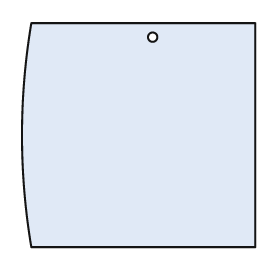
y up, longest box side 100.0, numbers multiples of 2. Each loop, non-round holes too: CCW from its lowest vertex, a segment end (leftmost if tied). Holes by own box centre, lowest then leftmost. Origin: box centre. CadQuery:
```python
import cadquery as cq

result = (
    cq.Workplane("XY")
    .moveTo(-46.0, -48.0)
    .lineTo(50.0, -48.0)
    .lineTo(50.0, 48.0)
    .lineTo(-46.0, 48.0)
    .threePointArc((-50.0, 0.0), (-46.0, -48.0))
    .close()
    .moveTo(6.0, 42.0)
    .circle(2.0)
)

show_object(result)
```